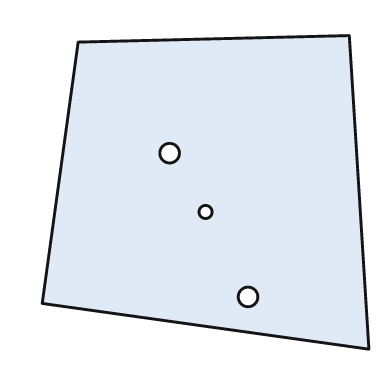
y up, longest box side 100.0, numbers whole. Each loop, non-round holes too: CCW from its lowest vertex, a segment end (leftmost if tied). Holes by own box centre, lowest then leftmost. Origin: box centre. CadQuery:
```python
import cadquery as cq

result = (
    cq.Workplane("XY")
    .moveTo(50.0, -48.0)
    .lineTo(44.0, 48.0)
    .lineTo(-39.0, 46.0)
    .lineTo(-50.0, -34.0)
    .close()
    .moveTo(13.0, -32.0)
    .circle(3.0)
    .moveTo(0.0, -6.0)
    .circle(2.0)
    .moveTo(-11.0, 12.0)
    .circle(3.0)
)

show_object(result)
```